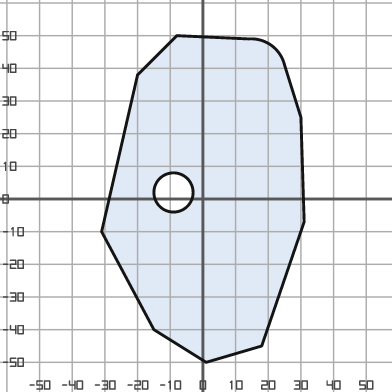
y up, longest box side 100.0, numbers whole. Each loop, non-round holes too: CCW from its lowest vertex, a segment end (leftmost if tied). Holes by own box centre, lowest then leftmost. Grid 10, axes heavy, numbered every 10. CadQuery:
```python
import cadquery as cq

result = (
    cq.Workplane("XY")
    .moveTo(1.0, -50.0)
    .lineTo(18.0, -45.0)
    .lineTo(31.0, -7.0)
    .lineTo(30.0, 25.0)
    .lineTo(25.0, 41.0)
    .threePointArc((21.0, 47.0), (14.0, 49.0))
    .lineTo(-8.0, 50.0)
    .lineTo(-20.0, 38.0)
    .lineTo(-31.0, -10.0)
    .lineTo(-15.0, -40.0)
    .close()
    .moveTo(-9.0, 2.0)
    .circle(6.0)
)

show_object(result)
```